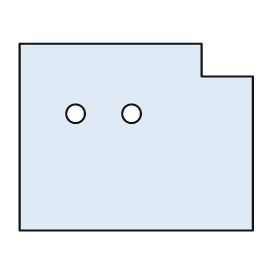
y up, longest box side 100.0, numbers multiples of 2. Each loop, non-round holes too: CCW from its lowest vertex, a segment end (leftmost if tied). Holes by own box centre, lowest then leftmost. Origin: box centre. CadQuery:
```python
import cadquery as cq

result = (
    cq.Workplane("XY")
    .moveTo(-50.0, -40.0)
    .lineTo(50.0, -40.0)
    .lineTo(50.0, 26.0)
    .lineTo(28.0, 26.0)
    .lineTo(28.0, 40.0)
    .lineTo(-50.0, 40.0)
    .close()
    .moveTo(-26.0, 10.0)
    .circle(4.0)
    .moveTo(-2.0, 10.0)
    .circle(4.0)
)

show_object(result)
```